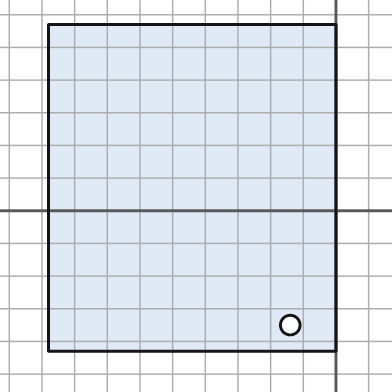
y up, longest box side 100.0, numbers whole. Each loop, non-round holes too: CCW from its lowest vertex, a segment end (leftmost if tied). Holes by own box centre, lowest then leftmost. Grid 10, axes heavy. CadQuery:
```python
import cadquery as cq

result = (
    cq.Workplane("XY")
    .moveTo(-88.0, -43.0)
    .lineTo(0.0, -43.0)
    .lineTo(0.0, 57.0)
    .lineTo(-88.0, 57.0)
    .close()
    .moveTo(-14.0, -35.0)
    .circle(3.0)
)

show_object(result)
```